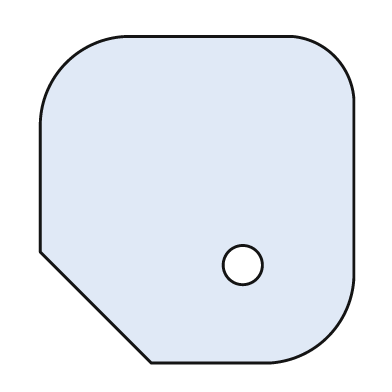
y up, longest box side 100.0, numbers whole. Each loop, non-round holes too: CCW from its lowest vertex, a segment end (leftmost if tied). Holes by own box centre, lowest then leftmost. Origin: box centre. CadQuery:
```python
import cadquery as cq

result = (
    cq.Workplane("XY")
    .moveTo(-14.0, -50.0)
    .lineTo(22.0, -50.0)
    .threePointArc((40.0, -42.0), (48.0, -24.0))
    .lineTo(48.0, 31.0)
    .threePointArc((42.0, 44.0), (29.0, 50.0))
    .lineTo(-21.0, 50.0)
    .threePointArc((-40.0, 42.0), (-48.0, 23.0))
    .lineTo(-48.0, -16.0)
    .close()
    .moveTo(14.0, -20.0)
    .circle(6.0)
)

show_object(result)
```